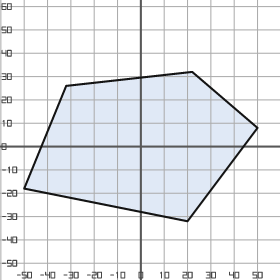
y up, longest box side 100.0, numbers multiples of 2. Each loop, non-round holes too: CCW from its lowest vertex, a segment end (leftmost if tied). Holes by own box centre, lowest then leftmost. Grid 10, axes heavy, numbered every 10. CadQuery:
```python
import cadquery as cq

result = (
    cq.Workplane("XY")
    .moveTo(20.0, -32.0)
    .lineTo(50.0, 8.0)
    .lineTo(22.0, 32.0)
    .lineTo(-32.0, 26.0)
    .lineTo(-50.0, -18.0)
    .close()
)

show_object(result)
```